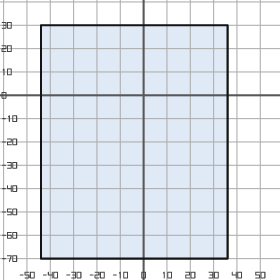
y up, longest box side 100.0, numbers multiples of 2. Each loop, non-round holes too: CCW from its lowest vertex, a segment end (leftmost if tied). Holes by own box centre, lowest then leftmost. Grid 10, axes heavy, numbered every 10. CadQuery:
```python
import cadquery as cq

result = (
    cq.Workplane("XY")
    .moveTo(-44.0, -70.0)
    .lineTo(36.0, -70.0)
    .lineTo(36.0, 30.0)
    .lineTo(-44.0, 30.0)
    .close()
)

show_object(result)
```